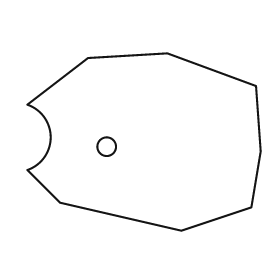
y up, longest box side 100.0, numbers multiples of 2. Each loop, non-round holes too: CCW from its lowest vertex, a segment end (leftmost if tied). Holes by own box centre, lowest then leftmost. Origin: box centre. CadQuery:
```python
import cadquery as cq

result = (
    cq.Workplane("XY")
    .moveTo(16.0, -38.0)
    .lineTo(46.0, -28.0)
    .lineTo(50.0, -4.0)
    .lineTo(48.0, 24.0)
    .lineTo(10.0, 38.0)
    .lineTo(-24.0, 36.0)
    .lineTo(-50.0, 16.0)
    .threePointArc((-40.0, 2.0), (-50.0, -12.0))
    .lineTo(-36.0, -26.0)
    .close()
    .moveTo(-16.0, -2.0)
    .circle(4.0)
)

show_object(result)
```